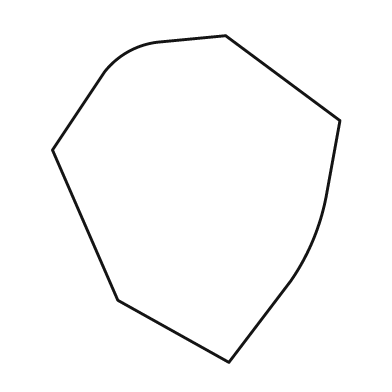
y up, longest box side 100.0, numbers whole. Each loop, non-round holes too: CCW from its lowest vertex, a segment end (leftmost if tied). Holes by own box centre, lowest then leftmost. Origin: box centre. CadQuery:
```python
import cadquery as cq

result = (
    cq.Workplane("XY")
    .moveTo(10.0, -50.0)
    .lineTo(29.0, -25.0)
    .threePointArc((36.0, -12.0), (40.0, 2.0))
    .lineTo(44.0, 24.0)
    .lineTo(9.0, 50.0)
    .lineTo(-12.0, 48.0)
    .threePointArc((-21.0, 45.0), (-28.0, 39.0))
    .lineTo(-44.0, 15.0)
    .lineTo(-24.0, -31.0)
    .close()
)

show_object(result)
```